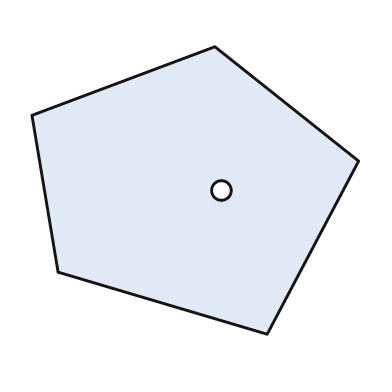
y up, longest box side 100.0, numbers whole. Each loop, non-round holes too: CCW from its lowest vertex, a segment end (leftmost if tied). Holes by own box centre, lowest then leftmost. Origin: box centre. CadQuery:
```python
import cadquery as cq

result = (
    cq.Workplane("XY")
    .moveTo(22.0, -44.0)
    .lineTo(50.0, 9.0)
    .lineTo(6.0, 44.0)
    .lineTo(-50.0, 23.0)
    .lineTo(-42.0, -25.0)
    .close()
    .moveTo(8.0, 0.0)
    .circle(3.0)
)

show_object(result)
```